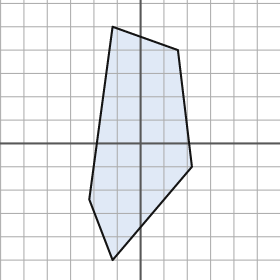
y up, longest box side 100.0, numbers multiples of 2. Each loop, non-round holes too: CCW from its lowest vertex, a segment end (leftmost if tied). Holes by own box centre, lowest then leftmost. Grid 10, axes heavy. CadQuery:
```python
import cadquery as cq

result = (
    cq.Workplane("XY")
    .moveTo(-12.0, -50.0)
    .lineTo(22.0, -10.0)
    .lineTo(16.0, 40.0)
    .lineTo(-12.0, 50.0)
    .lineTo(-22.0, -24.0)
    .close()
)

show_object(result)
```